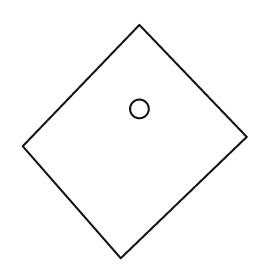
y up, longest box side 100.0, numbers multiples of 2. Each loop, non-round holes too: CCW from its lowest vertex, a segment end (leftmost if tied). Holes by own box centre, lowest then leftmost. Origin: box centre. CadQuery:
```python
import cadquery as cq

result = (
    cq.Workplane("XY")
    .moveTo(-6.0, -50.0)
    .lineTo(48.0, 2.0)
    .lineTo(2.0, 50.0)
    .lineTo(-48.0, -2.0)
    .close()
    .moveTo(2.0, 14.0)
    .circle(4.0)
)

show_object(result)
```